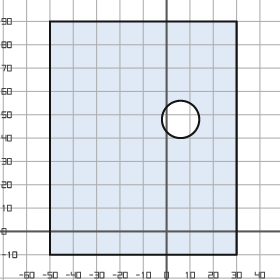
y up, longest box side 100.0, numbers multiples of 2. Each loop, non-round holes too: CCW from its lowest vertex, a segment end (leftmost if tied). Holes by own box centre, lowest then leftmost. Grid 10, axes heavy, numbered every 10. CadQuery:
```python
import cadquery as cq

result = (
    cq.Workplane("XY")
    .moveTo(-50.0, -10.0)
    .lineTo(30.0, -10.0)
    .lineTo(30.0, 90.0)
    .lineTo(-50.0, 90.0)
    .close()
    .moveTo(6.0, 48.0)
    .circle(8.0)
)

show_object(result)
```